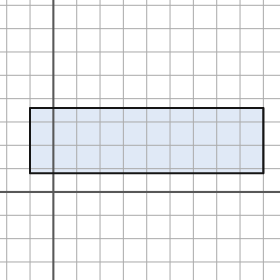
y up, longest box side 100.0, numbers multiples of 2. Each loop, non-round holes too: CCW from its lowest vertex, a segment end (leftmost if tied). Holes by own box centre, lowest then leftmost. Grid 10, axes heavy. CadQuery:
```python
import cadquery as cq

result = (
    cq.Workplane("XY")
    .moveTo(-10.0, 8.0)
    .lineTo(90.0, 8.0)
    .lineTo(90.0, 36.0)
    .lineTo(-10.0, 36.0)
    .close()
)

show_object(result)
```